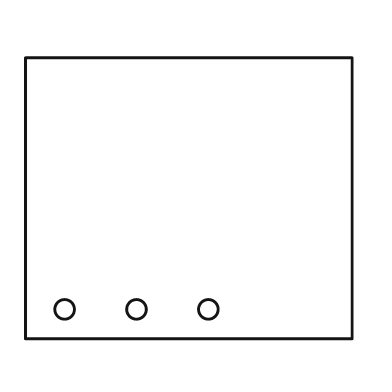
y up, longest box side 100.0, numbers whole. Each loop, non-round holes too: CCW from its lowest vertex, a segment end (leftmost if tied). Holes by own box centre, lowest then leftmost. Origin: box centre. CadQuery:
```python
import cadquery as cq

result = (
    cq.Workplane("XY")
    .moveTo(-50.0, -43.0)
    .lineTo(50.0, -43.0)
    .lineTo(50.0, 43.0)
    .lineTo(-50.0, 43.0)
    .close()
    .moveTo(-38.0, -34.0)
    .circle(3.0)
    .moveTo(-16.0, -34.0)
    .circle(3.0)
    .moveTo(6.0, -34.0)
    .circle(3.0)
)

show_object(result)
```